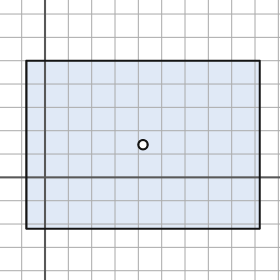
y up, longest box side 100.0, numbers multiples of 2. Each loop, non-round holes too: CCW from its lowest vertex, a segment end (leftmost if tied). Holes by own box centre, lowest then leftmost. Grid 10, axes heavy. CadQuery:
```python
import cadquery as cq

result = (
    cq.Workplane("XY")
    .moveTo(-8.0, -22.0)
    .lineTo(92.0, -22.0)
    .lineTo(92.0, 50.0)
    .lineTo(-8.0, 50.0)
    .close()
    .moveTo(42.0, 14.0)
    .circle(2.0)
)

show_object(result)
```